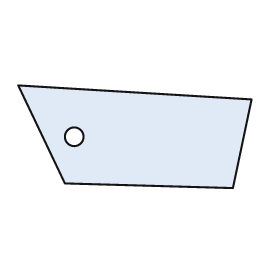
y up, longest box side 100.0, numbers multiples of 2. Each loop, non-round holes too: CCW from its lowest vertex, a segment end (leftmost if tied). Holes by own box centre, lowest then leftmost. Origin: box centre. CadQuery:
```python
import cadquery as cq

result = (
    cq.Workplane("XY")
    .moveTo(42.0, -22.0)
    .lineTo(50.0, 16.0)
    .lineTo(-50.0, 22.0)
    .lineTo(-30.0, -20.0)
    .close()
    .moveTo(-26.0, 0.0)
    .circle(4.0)
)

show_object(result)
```